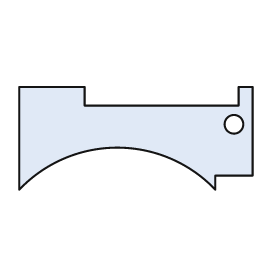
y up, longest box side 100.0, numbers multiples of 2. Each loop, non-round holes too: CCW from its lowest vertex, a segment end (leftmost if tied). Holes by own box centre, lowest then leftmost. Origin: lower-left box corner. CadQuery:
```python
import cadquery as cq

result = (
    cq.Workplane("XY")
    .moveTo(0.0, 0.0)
    .threePointArc((42.0, 18.0), (84.0, 0.0))
    .lineTo(84.0, 6.0)
    .lineTo(100.0, 6.0)
    .lineTo(100.0, 44.0)
    .lineTo(94.0, 44.0)
    .lineTo(94.0, 36.0)
    .lineTo(28.0, 36.0)
    .lineTo(28.0, 44.0)
    .lineTo(0.0, 44.0)
    .close()
    .moveTo(92.0, 28.0)
    .circle(4.0)
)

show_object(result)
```